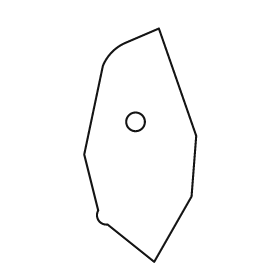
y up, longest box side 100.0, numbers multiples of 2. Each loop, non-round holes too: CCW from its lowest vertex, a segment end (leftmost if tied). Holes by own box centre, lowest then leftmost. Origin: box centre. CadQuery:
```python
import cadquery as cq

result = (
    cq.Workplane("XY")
    .moveTo(6.0, -50.0)
    .lineTo(22.0, -22.0)
    .lineTo(24.0, 4.0)
    .lineTo(8.0, 50.0)
    .lineTo(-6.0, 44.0)
    .threePointArc((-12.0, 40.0), (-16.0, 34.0))
    .lineTo(-24.0, -4.0)
    .lineTo(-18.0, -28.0)
    .threePointArc((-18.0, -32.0), (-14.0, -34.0))
    .close()
    .moveTo(-2.0, 10.0)
    .circle(4.0)
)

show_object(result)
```